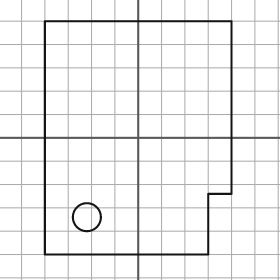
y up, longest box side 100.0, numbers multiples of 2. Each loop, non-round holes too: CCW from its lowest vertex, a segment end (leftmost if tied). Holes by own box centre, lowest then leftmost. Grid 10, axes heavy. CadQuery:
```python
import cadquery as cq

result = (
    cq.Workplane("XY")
    .moveTo(-40.0, -50.0)
    .lineTo(30.0, -50.0)
    .lineTo(30.0, -24.0)
    .lineTo(40.0, -24.0)
    .lineTo(40.0, 50.0)
    .lineTo(-40.0, 50.0)
    .close()
    .moveTo(-22.0, -34.0)
    .circle(6.0)
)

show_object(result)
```